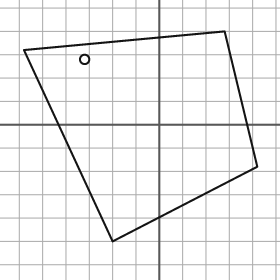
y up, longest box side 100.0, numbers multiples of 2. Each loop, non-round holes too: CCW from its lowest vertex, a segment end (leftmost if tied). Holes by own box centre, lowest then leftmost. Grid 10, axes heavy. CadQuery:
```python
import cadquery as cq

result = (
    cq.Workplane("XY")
    .moveTo(-20.0, -50.0)
    .lineTo(42.0, -18.0)
    .lineTo(28.0, 40.0)
    .lineTo(-58.0, 32.0)
    .close()
    .moveTo(-32.0, 28.0)
    .circle(2.0)
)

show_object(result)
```